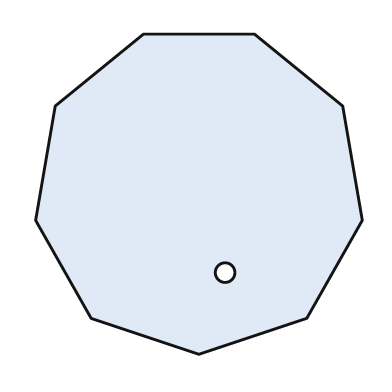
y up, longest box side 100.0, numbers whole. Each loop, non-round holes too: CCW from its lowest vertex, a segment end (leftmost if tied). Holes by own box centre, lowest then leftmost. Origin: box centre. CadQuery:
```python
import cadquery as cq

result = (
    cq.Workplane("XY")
    .moveTo(0.0, -49.0)
    .lineTo(33.0, -38.0)
    .lineTo(50.0, -8.0)
    .lineTo(44.0, 27.0)
    .lineTo(17.0, 49.0)
    .lineTo(-17.0, 49.0)
    .lineTo(-44.0, 27.0)
    .lineTo(-50.0, -8.0)
    .lineTo(-33.0, -38.0)
    .close()
    .moveTo(8.0, -24.0)
    .circle(3.0)
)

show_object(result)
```